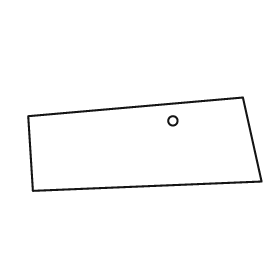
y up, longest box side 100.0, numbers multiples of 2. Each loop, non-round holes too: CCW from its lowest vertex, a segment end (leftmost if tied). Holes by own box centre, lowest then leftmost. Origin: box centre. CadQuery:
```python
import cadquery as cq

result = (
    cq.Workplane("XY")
    .moveTo(-48.0, -20.0)
    .lineTo(50.0, -16.0)
    .lineTo(42.0, 20.0)
    .lineTo(-50.0, 12.0)
    .close()
    .moveTo(12.0, 10.0)
    .circle(2.0)
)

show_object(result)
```